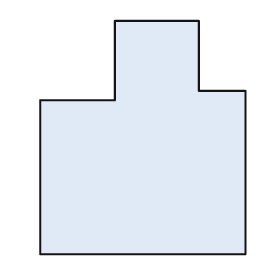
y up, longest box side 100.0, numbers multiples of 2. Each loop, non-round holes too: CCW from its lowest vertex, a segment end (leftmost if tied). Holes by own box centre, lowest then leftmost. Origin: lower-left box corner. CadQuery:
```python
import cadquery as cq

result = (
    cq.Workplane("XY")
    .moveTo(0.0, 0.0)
    .lineTo(88.0, 0.0)
    .lineTo(88.0, 70.0)
    .lineTo(68.0, 70.0)
    .lineTo(68.0, 100.0)
    .lineTo(32.0, 100.0)
    .lineTo(32.0, 66.0)
    .lineTo(0.0, 66.0)
    .close()
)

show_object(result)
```